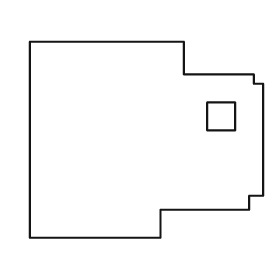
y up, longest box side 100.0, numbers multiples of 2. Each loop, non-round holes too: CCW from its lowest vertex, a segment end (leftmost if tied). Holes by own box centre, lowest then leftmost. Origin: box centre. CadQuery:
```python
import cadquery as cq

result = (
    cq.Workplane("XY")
    .moveTo(-50.0, -42.0)
    .lineTo(6.0, -42.0)
    .lineTo(6.0, -30.0)
    .lineTo(44.0, -30.0)
    .lineTo(44.0, -24.0)
    .lineTo(50.0, -24.0)
    .lineTo(50.0, 24.0)
    .lineTo(46.0, 24.0)
    .lineTo(46.0, 28.0)
    .lineTo(16.0, 28.0)
    .lineTo(16.0, 42.0)
    .lineTo(-50.0, 42.0)
    .close()
    .moveTo(26.0, 4.0)
    .lineTo(38.0, 4.0)
    .lineTo(38.0, 16.0)
    .lineTo(26.0, 16.0)
    .close()
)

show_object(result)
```